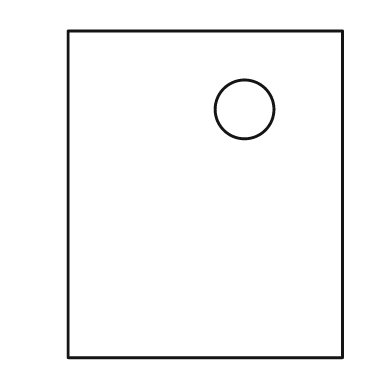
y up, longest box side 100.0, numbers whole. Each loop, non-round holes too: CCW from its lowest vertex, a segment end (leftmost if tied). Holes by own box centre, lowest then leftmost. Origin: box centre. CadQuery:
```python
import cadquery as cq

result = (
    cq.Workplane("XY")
    .moveTo(-42.0, -50.0)
    .lineTo(42.0, -50.0)
    .lineTo(42.0, 50.0)
    .lineTo(-42.0, 50.0)
    .close()
    .moveTo(12.0, 26.0)
    .circle(9.0)
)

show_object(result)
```